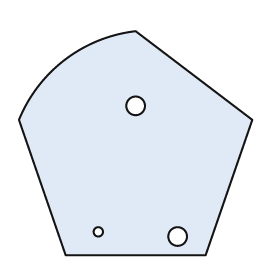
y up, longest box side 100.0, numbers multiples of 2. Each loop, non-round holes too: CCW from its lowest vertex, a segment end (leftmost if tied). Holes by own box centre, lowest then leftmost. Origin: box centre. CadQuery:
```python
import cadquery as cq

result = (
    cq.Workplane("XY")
    .moveTo(-30.0, -48.0)
    .lineTo(30.0, -48.0)
    .lineTo(50.0, 10.0)
    .lineTo(0.0, 48.0)
    .threePointArc((-30.0, 36.0), (-50.0, 10.0))
    .close()
    .moveTo(18.0, -40.0)
    .circle(4.0)
    .moveTo(-16.0, -38.0)
    .circle(2.0)
    .moveTo(0.0, 16.0)
    .circle(4.0)
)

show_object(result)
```